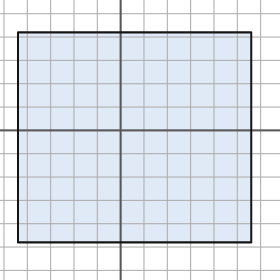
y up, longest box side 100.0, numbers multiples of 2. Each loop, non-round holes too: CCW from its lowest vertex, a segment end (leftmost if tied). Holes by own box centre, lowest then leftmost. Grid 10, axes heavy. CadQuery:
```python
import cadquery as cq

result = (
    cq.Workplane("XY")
    .moveTo(-44.0, -48.0)
    .lineTo(56.0, -48.0)
    .lineTo(56.0, 42.0)
    .lineTo(-44.0, 42.0)
    .close()
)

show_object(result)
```